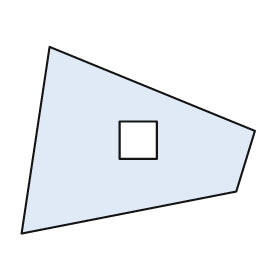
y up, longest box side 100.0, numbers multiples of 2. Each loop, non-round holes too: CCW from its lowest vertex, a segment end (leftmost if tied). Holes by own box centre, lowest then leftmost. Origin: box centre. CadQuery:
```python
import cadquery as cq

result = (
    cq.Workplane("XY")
    .moveTo(-50.0, -40.0)
    .lineTo(42.0, -22.0)
    .lineTo(50.0, 4.0)
    .lineTo(-38.0, 40.0)
    .close()
    .moveTo(-8.0, -8.0)
    .lineTo(8.0, -8.0)
    .lineTo(8.0, 8.0)
    .lineTo(-8.0, 8.0)
    .close()
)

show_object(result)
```